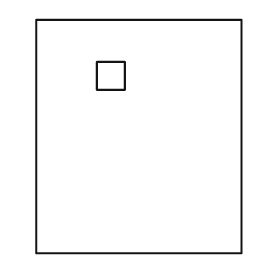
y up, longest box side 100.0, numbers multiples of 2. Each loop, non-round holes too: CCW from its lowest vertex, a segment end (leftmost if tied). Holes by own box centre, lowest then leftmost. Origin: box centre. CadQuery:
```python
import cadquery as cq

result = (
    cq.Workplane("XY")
    .moveTo(-44.0, -50.0)
    .lineTo(44.0, -50.0)
    .lineTo(44.0, 50.0)
    .lineTo(-44.0, 50.0)
    .close()
    .moveTo(-18.0, 20.0)
    .lineTo(-6.0, 20.0)
    .lineTo(-6.0, 32.0)
    .lineTo(-18.0, 32.0)
    .close()
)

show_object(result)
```